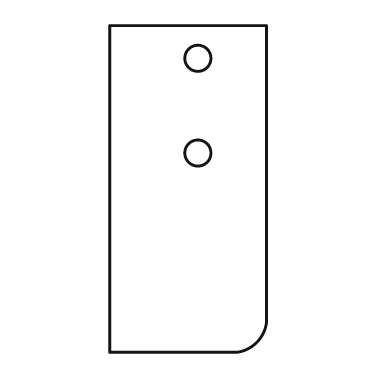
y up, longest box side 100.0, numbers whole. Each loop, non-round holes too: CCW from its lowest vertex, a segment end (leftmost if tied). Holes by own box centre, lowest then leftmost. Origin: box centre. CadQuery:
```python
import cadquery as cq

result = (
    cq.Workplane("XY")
    .moveTo(-24.0, -50.0)
    .lineTo(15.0, -50.0)
    .threePointArc((21.0, -47.0), (24.0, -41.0))
    .lineTo(24.0, 50.0)
    .lineTo(-24.0, 50.0)
    .close()
    .moveTo(3.0, 11.0)
    .circle(4.0)
    .moveTo(3.0, 40.0)
    .circle(4.0)
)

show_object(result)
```